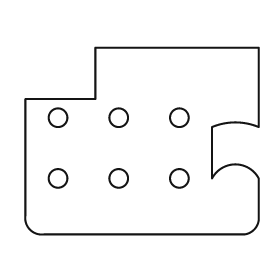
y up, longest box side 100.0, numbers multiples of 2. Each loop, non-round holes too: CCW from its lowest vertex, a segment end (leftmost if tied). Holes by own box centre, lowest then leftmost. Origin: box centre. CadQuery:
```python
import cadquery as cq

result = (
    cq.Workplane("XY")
    .moveTo(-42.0, -40.0)
    .lineTo(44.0, -40.0)
    .threePointArc((48.0, -38.0), (50.0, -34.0))
    .lineTo(50.0, -16.0)
    .threePointArc((40.0, -10.0), (30.0, -16.0))
    .lineTo(30.0, 6.0)
    .threePointArc((40.0, 8.0), (50.0, 6.0))
    .lineTo(50.0, 40.0)
    .lineTo(-20.0, 40.0)
    .lineTo(-20.0, 18.0)
    .lineTo(-50.0, 18.0)
    .lineTo(-50.0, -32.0)
    .threePointArc((-48.0, -38.0), (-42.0, -40.0))
    .close()
    .moveTo(-36.0, -16.0)
    .circle(4.0)
    .moveTo(-10.0, -16.0)
    .circle(4.0)
    .moveTo(16.0, -16.0)
    .circle(4.0)
    .moveTo(-36.0, 10.0)
    .circle(4.0)
    .moveTo(-10.0, 10.0)
    .circle(4.0)
    .moveTo(16.0, 10.0)
    .circle(4.0)
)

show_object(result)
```